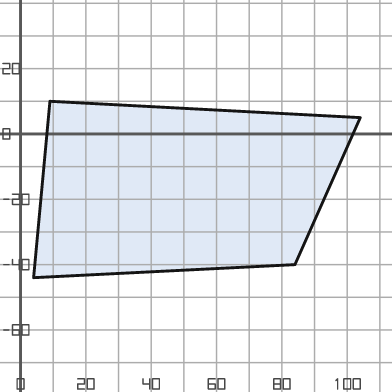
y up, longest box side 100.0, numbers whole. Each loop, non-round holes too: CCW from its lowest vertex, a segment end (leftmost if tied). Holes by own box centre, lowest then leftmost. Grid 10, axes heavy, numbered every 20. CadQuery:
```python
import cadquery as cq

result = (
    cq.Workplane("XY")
    .moveTo(4.0, -44.0)
    .lineTo(84.0, -40.0)
    .lineTo(104.0, 5.0)
    .lineTo(9.0, 10.0)
    .close()
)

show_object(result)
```